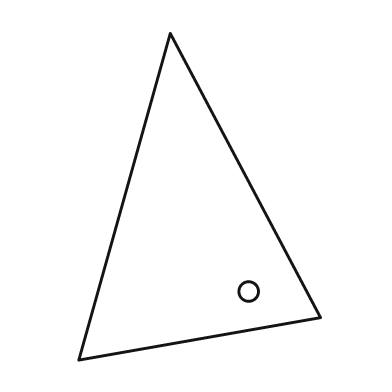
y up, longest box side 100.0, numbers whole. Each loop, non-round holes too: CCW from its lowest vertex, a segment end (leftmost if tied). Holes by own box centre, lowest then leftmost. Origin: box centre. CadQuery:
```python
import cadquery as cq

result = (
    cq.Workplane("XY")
    .moveTo(-37.0, -50.0)
    .lineTo(37.0, -37.0)
    .lineTo(-9.0, 50.0)
    .close()
    .moveTo(15.0, -29.0)
    .circle(3.0)
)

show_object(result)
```